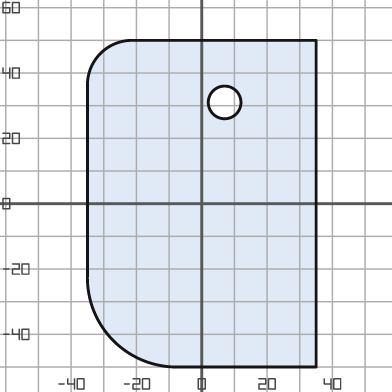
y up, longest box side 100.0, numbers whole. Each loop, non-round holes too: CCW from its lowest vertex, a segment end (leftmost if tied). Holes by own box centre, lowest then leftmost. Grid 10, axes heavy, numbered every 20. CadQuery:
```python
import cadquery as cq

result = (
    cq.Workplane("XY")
    .moveTo(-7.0, -50.0)
    .lineTo(35.0, -50.0)
    .lineTo(35.0, 50.0)
    .lineTo(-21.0, 50.0)
    .threePointArc((-31.0, 46.0), (-35.0, 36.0))
    .lineTo(-35.0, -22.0)
    .threePointArc((-27.0, -42.0), (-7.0, -50.0))
    .close()
    .moveTo(7.0, 31.0)
    .circle(5.0)
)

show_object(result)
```